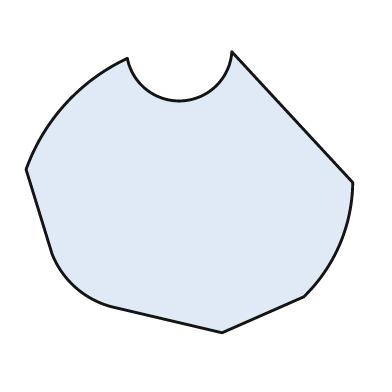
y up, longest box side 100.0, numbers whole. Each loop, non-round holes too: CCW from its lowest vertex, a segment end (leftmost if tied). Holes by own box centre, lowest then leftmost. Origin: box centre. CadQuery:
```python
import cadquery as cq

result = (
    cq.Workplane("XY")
    .moveTo(10.0, -43.0)
    .lineTo(35.0, -32.0)
    .threePointArc((46.0, -16.0), (50.0, 3.0))
    .lineTo(13.0, 43.0)
    .threePointArc((-2.0, 28.0), (-19.0, 41.0))
    .threePointArc((-38.0, 27.0), (-50.0, 7.0))
    .lineTo(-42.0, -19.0)
    .threePointArc((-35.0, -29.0), (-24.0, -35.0))
    .close()
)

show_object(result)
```